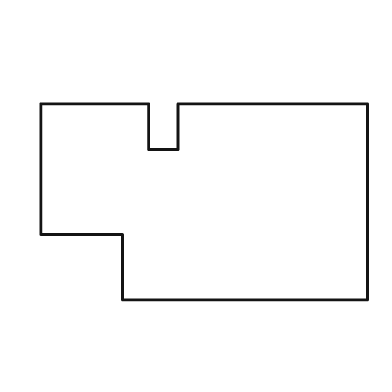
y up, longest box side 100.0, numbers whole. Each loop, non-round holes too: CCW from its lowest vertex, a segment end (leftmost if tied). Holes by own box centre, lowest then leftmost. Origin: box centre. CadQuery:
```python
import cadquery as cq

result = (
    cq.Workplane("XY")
    .moveTo(-25.0, -30.0)
    .lineTo(50.0, -30.0)
    .lineTo(50.0, 30.0)
    .lineTo(-8.0, 30.0)
    .lineTo(-8.0, 16.0)
    .lineTo(-17.0, 16.0)
    .lineTo(-17.0, 30.0)
    .lineTo(-50.0, 30.0)
    .lineTo(-50.0, -10.0)
    .lineTo(-25.0, -10.0)
    .close()
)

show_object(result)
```